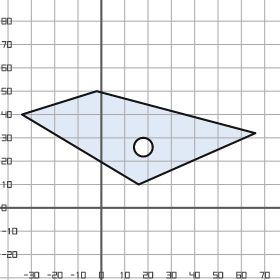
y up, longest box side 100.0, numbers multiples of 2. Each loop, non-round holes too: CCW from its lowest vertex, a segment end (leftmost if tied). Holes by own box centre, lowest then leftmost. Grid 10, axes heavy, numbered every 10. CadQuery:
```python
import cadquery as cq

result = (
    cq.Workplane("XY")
    .moveTo(16.0, 10.0)
    .lineTo(66.0, 32.0)
    .lineTo(-2.0, 50.0)
    .lineTo(-34.0, 40.0)
    .close()
    .moveTo(18.0, 26.0)
    .circle(4.0)
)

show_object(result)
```